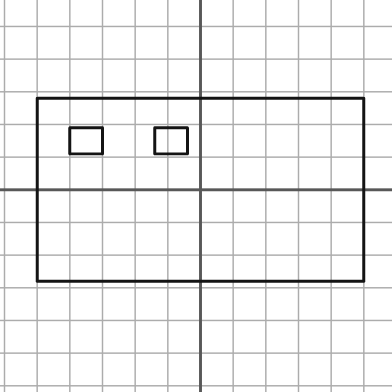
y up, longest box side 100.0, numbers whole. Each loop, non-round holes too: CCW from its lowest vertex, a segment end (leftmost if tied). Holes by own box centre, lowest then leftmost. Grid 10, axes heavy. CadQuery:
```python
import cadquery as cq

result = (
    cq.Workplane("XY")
    .moveTo(-50.0, -28.0)
    .lineTo(50.0, -28.0)
    .lineTo(50.0, 28.0)
    .lineTo(-50.0, 28.0)
    .close()
    .moveTo(-40.0, 11.0)
    .lineTo(-30.0, 11.0)
    .lineTo(-30.0, 19.0)
    .lineTo(-40.0, 19.0)
    .close()
    .moveTo(-14.0, 11.0)
    .lineTo(-4.0, 11.0)
    .lineTo(-4.0, 19.0)
    .lineTo(-14.0, 19.0)
    .close()
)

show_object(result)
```